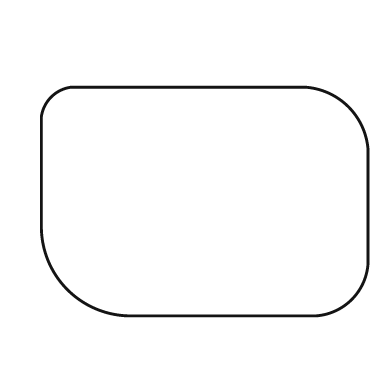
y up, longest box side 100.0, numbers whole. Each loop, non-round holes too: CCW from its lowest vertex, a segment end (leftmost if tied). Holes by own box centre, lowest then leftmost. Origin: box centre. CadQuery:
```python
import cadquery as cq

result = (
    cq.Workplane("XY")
    .moveTo(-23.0, -35.0)
    .lineTo(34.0, -35.0)
    .threePointArc((45.0, -30.0), (50.0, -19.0))
    .lineTo(50.0, 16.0)
    .threePointArc((44.0, 29.0), (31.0, 35.0))
    .lineTo(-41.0, 35.0)
    .threePointArc((-47.0, 32.0), (-50.0, 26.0))
    .lineTo(-50.0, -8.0)
    .threePointArc((-42.0, -27.0), (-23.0, -35.0))
    .close()
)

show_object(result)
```